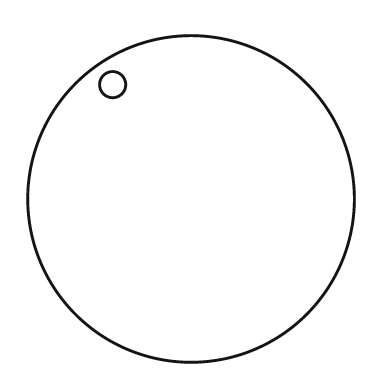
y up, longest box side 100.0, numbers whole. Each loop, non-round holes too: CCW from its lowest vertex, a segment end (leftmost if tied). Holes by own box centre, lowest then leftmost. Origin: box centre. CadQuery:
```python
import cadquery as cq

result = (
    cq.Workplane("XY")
    .moveTo(0.0, 0.0)
    .circle(50.0)
    .moveTo(-24.0, 35.0)
    .circle(4.0)
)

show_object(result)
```